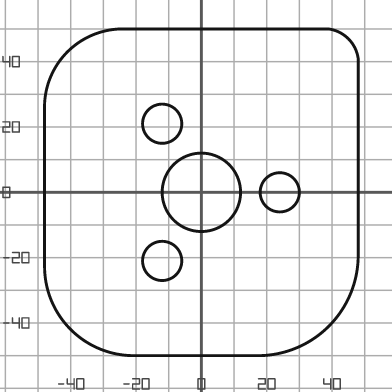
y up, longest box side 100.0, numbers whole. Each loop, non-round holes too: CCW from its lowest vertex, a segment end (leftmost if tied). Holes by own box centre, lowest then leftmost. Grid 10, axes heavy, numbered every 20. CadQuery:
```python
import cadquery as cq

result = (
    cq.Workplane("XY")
    .moveTo(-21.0, -50.0)
    .lineTo(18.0, -50.0)
    .threePointArc((39.0, -41.0), (48.0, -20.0))
    .lineTo(48.0, 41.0)
    .threePointArc((45.0, 47.0), (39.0, 50.0))
    .lineTo(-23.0, 50.0)
    .threePointArc((-41.0, 43.0), (-48.0, 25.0))
    .lineTo(-48.0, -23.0)
    .threePointArc((-40.0, -42.0), (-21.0, -50.0))
    .close()
    .moveTo(-12.0, -21.0)
    .circle(6.0)
    .moveTo(0.0, 0.0)
    .circle(12.0)
    .moveTo(24.0, 0.0)
    .circle(6.0)
    .moveTo(-12.0, 21.0)
    .circle(6.0)
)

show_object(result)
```